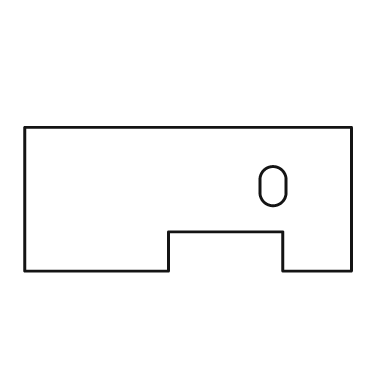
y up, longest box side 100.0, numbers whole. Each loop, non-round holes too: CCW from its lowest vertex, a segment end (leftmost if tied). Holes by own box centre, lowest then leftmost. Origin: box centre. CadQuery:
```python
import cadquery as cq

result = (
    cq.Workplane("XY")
    .moveTo(-50.0, -22.0)
    .lineTo(-6.0, -22.0)
    .lineTo(-6.0, -10.0)
    .lineTo(29.0, -10.0)
    .lineTo(29.0, -22.0)
    .lineTo(50.0, -22.0)
    .lineTo(50.0, 22.0)
    .lineTo(-50.0, 22.0)
    .close()
    .moveTo(22.0, 2.0)
    .threePointArc((26.0, -2.0), (30.0, 2.0))
    .lineTo(30.0, 6.0)
    .threePointArc((26.0, 10.0), (22.0, 6.0))
    .close()
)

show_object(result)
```